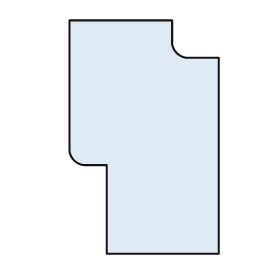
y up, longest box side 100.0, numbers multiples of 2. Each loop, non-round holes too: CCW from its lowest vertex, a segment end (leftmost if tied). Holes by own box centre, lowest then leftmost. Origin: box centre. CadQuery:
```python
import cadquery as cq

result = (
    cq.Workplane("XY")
    .moveTo(-16.0, -50.0)
    .lineTo(32.0, -50.0)
    .lineTo(32.0, 34.0)
    .lineTo(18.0, 34.0)
    .threePointArc((14.0, 36.0), (12.0, 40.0))
    .lineTo(12.0, 50.0)
    .lineTo(-32.0, 50.0)
    .lineTo(-32.0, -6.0)
    .threePointArc((-30.0, -10.0), (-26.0, -12.0))
    .lineTo(-16.0, -12.0)
    .close()
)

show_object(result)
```